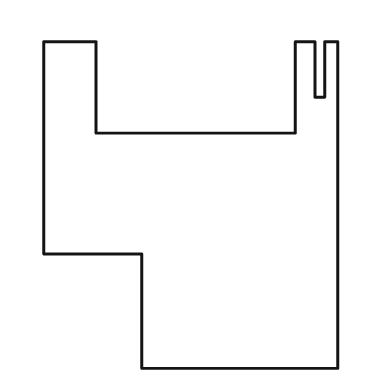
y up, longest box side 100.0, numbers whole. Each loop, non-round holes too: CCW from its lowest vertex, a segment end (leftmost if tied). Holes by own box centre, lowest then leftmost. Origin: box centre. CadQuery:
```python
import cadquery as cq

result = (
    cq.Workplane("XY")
    .moveTo(-15.0, -50.0)
    .lineTo(45.0, -50.0)
    .lineTo(45.0, 50.0)
    .lineTo(41.0, 50.0)
    .lineTo(41.0, 33.0)
    .lineTo(38.0, 33.0)
    .lineTo(38.0, 50.0)
    .lineTo(32.0, 50.0)
    .lineTo(32.0, 22.0)
    .lineTo(-29.0, 22.0)
    .lineTo(-29.0, 50.0)
    .lineTo(-45.0, 50.0)
    .lineTo(-45.0, -15.0)
    .lineTo(-15.0, -15.0)
    .close()
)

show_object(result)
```